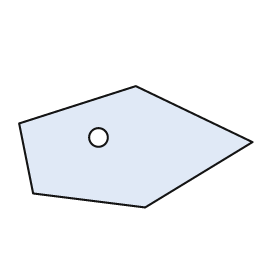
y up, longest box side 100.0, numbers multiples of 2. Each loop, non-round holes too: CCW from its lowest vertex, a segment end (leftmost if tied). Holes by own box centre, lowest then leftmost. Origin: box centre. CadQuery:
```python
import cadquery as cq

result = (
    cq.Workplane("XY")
    .moveTo(4.0, -26.0)
    .lineTo(50.0, 2.0)
    .lineTo(0.0, 26.0)
    .lineTo(-50.0, 10.0)
    .lineTo(-44.0, -20.0)
    .close()
    .moveTo(-16.0, 4.0)
    .circle(4.0)
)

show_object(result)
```